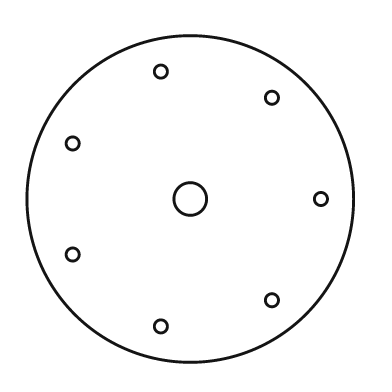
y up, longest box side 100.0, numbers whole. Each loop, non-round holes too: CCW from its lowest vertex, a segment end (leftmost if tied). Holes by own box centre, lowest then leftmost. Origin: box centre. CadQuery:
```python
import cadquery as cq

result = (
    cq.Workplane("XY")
    .moveTo(0.0, 0.0)
    .circle(50.0)
    .moveTo(-9.0, -39.0)
    .circle(2.0)
    .moveTo(25.0, -31.0)
    .circle(2.0)
    .moveTo(-36.0, -17.0)
    .circle(2.0)
    .moveTo(0.0, 0.0)
    .circle(5.0)
    .moveTo(40.0, 0.0)
    .circle(2.0)
    .moveTo(-36.0, 17.0)
    .circle(2.0)
    .moveTo(25.0, 31.0)
    .circle(2.0)
    .moveTo(-9.0, 39.0)
    .circle(2.0)
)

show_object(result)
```